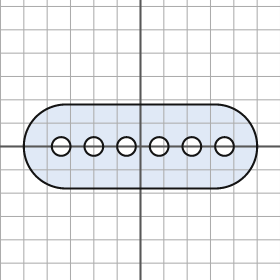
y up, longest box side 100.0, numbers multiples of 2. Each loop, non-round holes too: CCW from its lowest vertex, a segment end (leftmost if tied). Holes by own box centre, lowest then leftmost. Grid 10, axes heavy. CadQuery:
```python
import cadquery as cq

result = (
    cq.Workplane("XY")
    .moveTo(-32.0, -18.0)
    .lineTo(32.0, -18.0)
    .threePointArc((50.0, 0.0), (32.0, 18.0))
    .lineTo(-32.0, 18.0)
    .threePointArc((-50.0, 0.0), (-32.0, -18.0))
    .close()
    .moveTo(-34.0, 0.0)
    .circle(4.0)
    .moveTo(-20.0, 0.0)
    .circle(4.0)
    .moveTo(-6.0, 0.0)
    .circle(4.0)
    .moveTo(8.0, 0.0)
    .circle(4.0)
    .moveTo(22.0, 0.0)
    .circle(4.0)
    .moveTo(36.0, 0.0)
    .circle(4.0)
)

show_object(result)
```